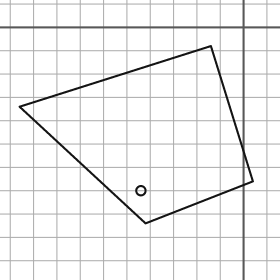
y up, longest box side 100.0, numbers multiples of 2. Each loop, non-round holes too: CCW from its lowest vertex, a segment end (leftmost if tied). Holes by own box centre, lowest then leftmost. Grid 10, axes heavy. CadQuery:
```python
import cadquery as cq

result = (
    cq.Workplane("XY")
    .moveTo(-42.0, -84.0)
    .lineTo(4.0, -66.0)
    .lineTo(-14.0, -8.0)
    .lineTo(-96.0, -34.0)
    .close()
    .moveTo(-44.0, -70.0)
    .circle(2.0)
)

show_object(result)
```